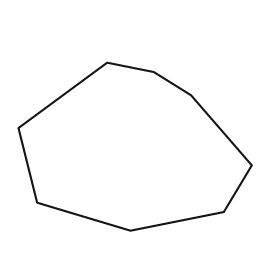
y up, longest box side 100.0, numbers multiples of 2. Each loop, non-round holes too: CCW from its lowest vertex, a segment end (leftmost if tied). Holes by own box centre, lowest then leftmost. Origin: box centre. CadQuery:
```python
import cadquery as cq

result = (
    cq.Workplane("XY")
    .moveTo(-2.0, -36.0)
    .lineTo(38.0, -28.0)
    .lineTo(50.0, -8.0)
    .lineTo(24.0, 22.0)
    .lineTo(8.0, 32.0)
    .lineTo(-12.0, 36.0)
    .lineTo(-50.0, 8.0)
    .lineTo(-42.0, -24.0)
    .close()
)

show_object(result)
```